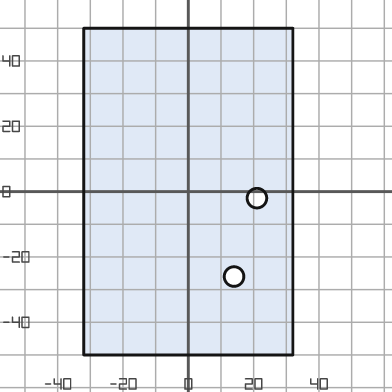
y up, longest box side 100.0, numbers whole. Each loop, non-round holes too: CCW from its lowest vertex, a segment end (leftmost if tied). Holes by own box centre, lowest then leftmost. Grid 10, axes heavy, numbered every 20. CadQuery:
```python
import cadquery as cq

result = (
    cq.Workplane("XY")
    .moveTo(-32.0, -50.0)
    .lineTo(32.0, -50.0)
    .lineTo(32.0, 50.0)
    .lineTo(-32.0, 50.0)
    .close()
    .moveTo(14.0, -26.0)
    .circle(3.0)
    .moveTo(21.0, -2.0)
    .circle(3.0)
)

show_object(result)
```